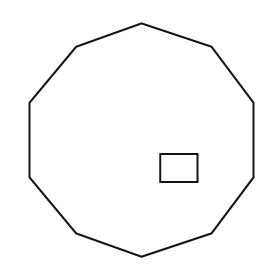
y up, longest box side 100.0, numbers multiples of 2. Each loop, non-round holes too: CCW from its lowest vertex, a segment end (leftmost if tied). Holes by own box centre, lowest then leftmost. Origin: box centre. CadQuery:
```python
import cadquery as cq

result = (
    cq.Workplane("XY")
    .moveTo(0.0, -50.0)
    .lineTo(30.0, -40.0)
    .lineTo(48.0, -16.0)
    .lineTo(48.0, 16.0)
    .lineTo(30.0, 40.0)
    .lineTo(0.0, 50.0)
    .lineTo(-28.0, 40.0)
    .lineTo(-48.0, 16.0)
    .lineTo(-48.0, -16.0)
    .lineTo(-28.0, -40.0)
    .close()
    .moveTo(8.0, -18.0)
    .lineTo(24.0, -18.0)
    .lineTo(24.0, -6.0)
    .lineTo(8.0, -6.0)
    .close()
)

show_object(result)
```